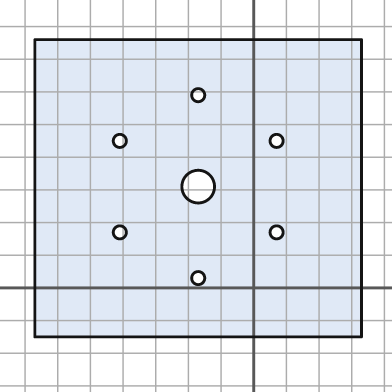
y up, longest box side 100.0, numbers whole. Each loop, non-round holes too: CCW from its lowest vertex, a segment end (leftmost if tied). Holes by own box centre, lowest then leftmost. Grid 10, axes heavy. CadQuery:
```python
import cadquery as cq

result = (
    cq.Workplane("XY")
    .moveTo(-67.0, -15.0)
    .lineTo(33.0, -15.0)
    .lineTo(33.0, 76.0)
    .lineTo(-67.0, 76.0)
    .close()
    .moveTo(-17.0, 3.0)
    .circle(2.0)
    .moveTo(-41.0, 17.0)
    .circle(2.0)
    .moveTo(7.0, 17.0)
    .circle(2.0)
    .moveTo(-17.0, 31.0)
    .circle(5.0)
    .moveTo(-41.0, 45.0)
    .circle(2.0)
    .moveTo(7.0, 45.0)
    .circle(2.0)
    .moveTo(-17.0, 59.0)
    .circle(2.0)
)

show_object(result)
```